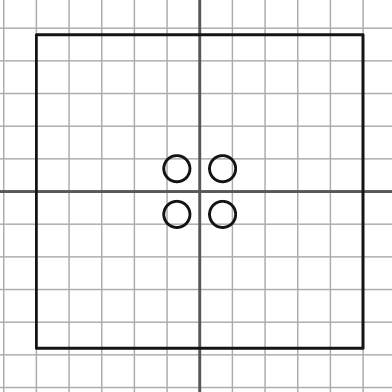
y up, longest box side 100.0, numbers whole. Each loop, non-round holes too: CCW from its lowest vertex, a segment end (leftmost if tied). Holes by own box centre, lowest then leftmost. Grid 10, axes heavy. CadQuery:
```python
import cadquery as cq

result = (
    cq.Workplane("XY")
    .moveTo(-50.0, -48.0)
    .lineTo(50.0, -48.0)
    .lineTo(50.0, 48.0)
    .lineTo(-50.0, 48.0)
    .close()
    .moveTo(-7.0, -7.0)
    .circle(4.0)
    .moveTo(7.0, -7.0)
    .circle(4.0)
    .moveTo(-7.0, 7.0)
    .circle(4.0)
    .moveTo(7.0, 7.0)
    .circle(4.0)
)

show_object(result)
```